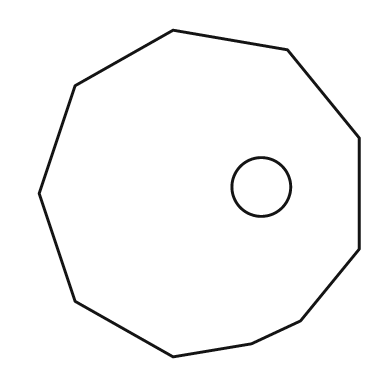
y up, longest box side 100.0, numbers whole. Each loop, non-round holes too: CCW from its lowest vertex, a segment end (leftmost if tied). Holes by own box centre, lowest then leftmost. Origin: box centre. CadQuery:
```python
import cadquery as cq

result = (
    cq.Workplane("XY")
    .moveTo(-8.0, -50.0)
    .lineTo(16.0, -46.0)
    .lineTo(31.0, -39.0)
    .lineTo(49.0, -17.0)
    .lineTo(49.0, 17.0)
    .lineTo(27.0, 44.0)
    .lineTo(-8.0, 50.0)
    .lineTo(-38.0, 33.0)
    .lineTo(-49.0, 0.0)
    .lineTo(-38.0, -33.0)
    .close()
    .moveTo(19.0, 2.0)
    .circle(9.0)
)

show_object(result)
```